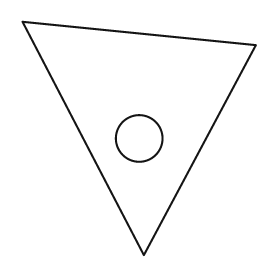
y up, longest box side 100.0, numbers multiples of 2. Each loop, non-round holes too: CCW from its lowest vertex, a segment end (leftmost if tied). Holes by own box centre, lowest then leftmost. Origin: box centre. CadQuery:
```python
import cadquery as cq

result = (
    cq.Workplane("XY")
    .moveTo(2.0, -50.0)
    .lineTo(50.0, 40.0)
    .lineTo(-50.0, 50.0)
    .close()
    .moveTo(0.0, 0.0)
    .circle(10.0)
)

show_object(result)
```